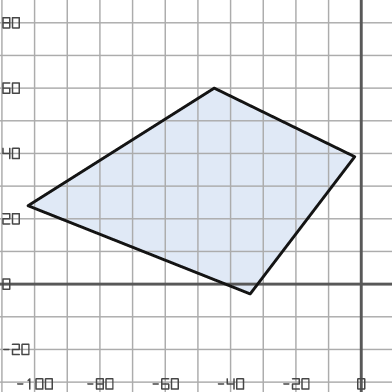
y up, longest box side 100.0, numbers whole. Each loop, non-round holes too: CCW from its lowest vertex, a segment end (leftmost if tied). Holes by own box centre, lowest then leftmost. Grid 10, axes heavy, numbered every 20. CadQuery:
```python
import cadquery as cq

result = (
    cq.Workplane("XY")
    .moveTo(-34.0, -3.0)
    .lineTo(-2.0, 39.0)
    .lineTo(-45.0, 60.0)
    .lineTo(-102.0, 24.0)
    .close()
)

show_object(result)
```